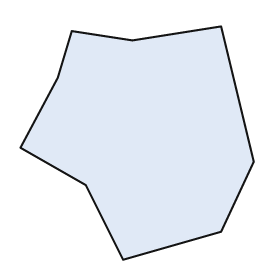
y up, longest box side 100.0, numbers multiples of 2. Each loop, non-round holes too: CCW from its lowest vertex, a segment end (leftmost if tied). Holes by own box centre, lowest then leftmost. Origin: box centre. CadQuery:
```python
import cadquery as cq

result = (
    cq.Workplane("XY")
    .moveTo(-6.0, -50.0)
    .lineTo(36.0, -38.0)
    .lineTo(50.0, -8.0)
    .lineTo(36.0, 50.0)
    .lineTo(-2.0, 44.0)
    .lineTo(-28.0, 48.0)
    .lineTo(-34.0, 28.0)
    .lineTo(-50.0, -2.0)
    .lineTo(-22.0, -18.0)
    .close()
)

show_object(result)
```